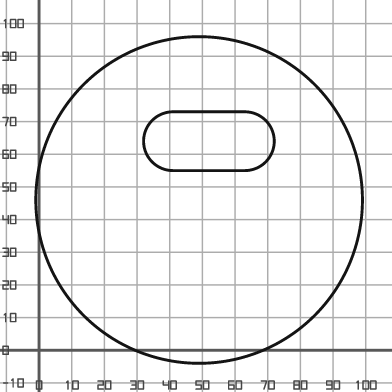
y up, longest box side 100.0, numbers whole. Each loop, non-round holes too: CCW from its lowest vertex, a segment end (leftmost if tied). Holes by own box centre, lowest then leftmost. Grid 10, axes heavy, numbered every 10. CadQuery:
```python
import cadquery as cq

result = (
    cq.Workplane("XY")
    .moveTo(49.0, 46.0)
    .circle(50.0)
    .moveTo(41.0, 55.0)
    .lineTo(63.0, 55.0)
    .threePointArc((72.0, 64.0), (63.0, 73.0))
    .lineTo(41.0, 73.0)
    .threePointArc((32.0, 64.0), (41.0, 55.0))
    .close()
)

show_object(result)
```